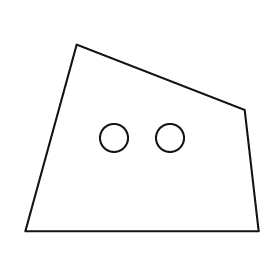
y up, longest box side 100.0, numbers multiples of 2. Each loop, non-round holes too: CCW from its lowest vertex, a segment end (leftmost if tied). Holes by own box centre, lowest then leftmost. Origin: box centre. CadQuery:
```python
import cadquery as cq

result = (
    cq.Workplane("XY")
    .moveTo(-50.0, -40.0)
    .lineTo(50.0, -40.0)
    .lineTo(44.0, 12.0)
    .lineTo(-28.0, 40.0)
    .close()
    .moveTo(-12.0, 0.0)
    .circle(6.0)
    .moveTo(12.0, 0.0)
    .circle(6.0)
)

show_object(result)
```